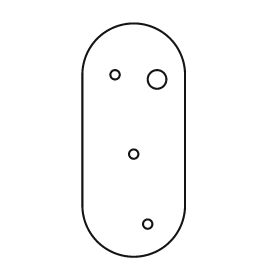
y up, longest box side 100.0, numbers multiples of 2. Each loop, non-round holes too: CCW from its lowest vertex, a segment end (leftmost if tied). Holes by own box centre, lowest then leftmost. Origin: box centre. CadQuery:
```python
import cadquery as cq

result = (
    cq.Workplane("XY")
    .moveTo(-22.0, -28.0)
    .threePointArc((0.0, -50.0), (22.0, -28.0))
    .lineTo(22.0, 28.0)
    .threePointArc((0.0, 50.0), (-22.0, 28.0))
    .close()
    .moveTo(6.0, -36.0)
    .circle(2.0)
    .moveTo(0.0, -6.0)
    .circle(2.0)
    .moveTo(10.0, 26.0)
    .circle(4.0)
    .moveTo(-8.0, 28.0)
    .circle(2.0)
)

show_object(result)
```